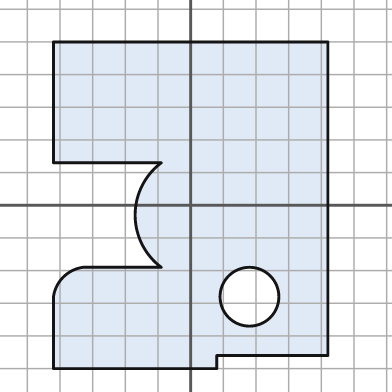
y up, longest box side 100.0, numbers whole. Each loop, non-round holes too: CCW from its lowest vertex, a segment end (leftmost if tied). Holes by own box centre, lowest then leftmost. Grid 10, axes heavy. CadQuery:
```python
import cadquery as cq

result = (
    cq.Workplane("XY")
    .moveTo(-42.0, -50.0)
    .lineTo(8.0, -50.0)
    .lineTo(8.0, -46.0)
    .lineTo(42.0, -46.0)
    .lineTo(42.0, 50.0)
    .lineTo(-42.0, 50.0)
    .lineTo(-42.0, 13.0)
    .lineTo(-9.0, 13.0)
    .threePointArc((-17.0, -3.0), (-9.0, -19.0))
    .lineTo(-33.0, -19.0)
    .threePointArc((-39.0, -22.0), (-42.0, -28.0))
    .close()
    .moveTo(18.0, -28.0)
    .circle(9.0)
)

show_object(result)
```